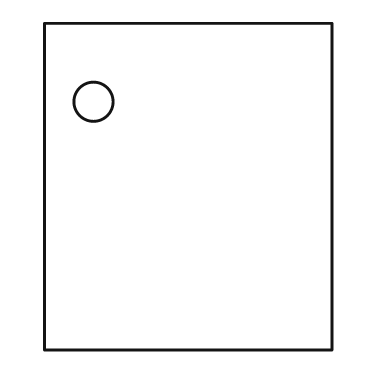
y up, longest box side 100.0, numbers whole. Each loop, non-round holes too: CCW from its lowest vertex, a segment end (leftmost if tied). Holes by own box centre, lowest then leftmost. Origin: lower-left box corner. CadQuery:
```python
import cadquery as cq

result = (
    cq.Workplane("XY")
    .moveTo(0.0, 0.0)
    .lineTo(88.0, 0.0)
    .lineTo(88.0, 100.0)
    .lineTo(0.0, 100.0)
    .close()
    .moveTo(15.0, 76.0)
    .circle(6.0)
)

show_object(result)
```